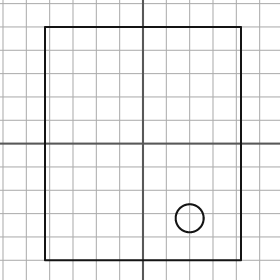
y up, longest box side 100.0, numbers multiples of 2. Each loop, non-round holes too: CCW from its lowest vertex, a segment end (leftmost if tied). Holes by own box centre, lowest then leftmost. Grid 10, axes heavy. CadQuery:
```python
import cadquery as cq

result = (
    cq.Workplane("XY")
    .moveTo(-42.0, -50.0)
    .lineTo(42.0, -50.0)
    .lineTo(42.0, 50.0)
    .lineTo(-42.0, 50.0)
    .close()
    .moveTo(20.0, -32.0)
    .circle(6.0)
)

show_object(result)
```